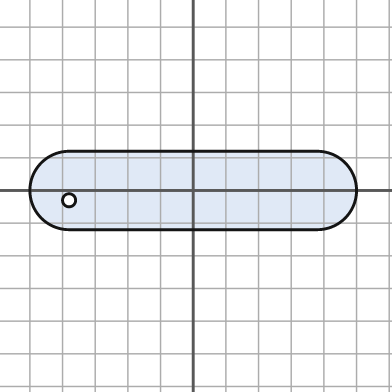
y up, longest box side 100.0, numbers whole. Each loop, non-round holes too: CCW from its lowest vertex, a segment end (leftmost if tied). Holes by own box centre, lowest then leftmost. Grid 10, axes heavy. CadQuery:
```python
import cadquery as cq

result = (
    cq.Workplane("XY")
    .moveTo(-38.0, -12.0)
    .lineTo(38.0, -12.0)
    .threePointArc((50.0, 0.0), (38.0, 12.0))
    .lineTo(-38.0, 12.0)
    .threePointArc((-50.0, 0.0), (-38.0, -12.0))
    .close()
    .moveTo(-38.0, -3.0)
    .circle(2.0)
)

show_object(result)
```